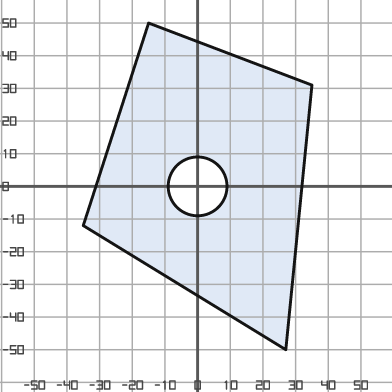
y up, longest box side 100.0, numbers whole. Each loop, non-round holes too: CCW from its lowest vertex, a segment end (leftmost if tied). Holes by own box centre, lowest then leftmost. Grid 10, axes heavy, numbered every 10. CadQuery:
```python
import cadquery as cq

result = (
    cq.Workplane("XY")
    .moveTo(27.0, -50.0)
    .lineTo(35.0, 31.0)
    .lineTo(-15.0, 50.0)
    .lineTo(-35.0, -12.0)
    .close()
    .moveTo(0.0, 0.0)
    .circle(9.0)
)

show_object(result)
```